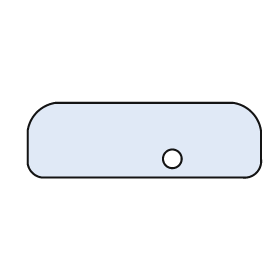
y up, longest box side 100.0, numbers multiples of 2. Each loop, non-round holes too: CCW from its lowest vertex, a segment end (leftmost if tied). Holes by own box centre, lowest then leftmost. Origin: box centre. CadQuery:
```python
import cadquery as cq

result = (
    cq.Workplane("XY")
    .moveTo(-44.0, -16.0)
    .lineTo(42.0, -16.0)
    .threePointArc((48.0, -14.0), (50.0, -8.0))
    .lineTo(50.0, 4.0)
    .threePointArc((46.0, 12.0), (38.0, 16.0))
    .lineTo(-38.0, 16.0)
    .threePointArc((-46.0, 12.0), (-50.0, 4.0))
    .lineTo(-50.0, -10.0)
    .threePointArc((-48.0, -14.0), (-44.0, -16.0))
    .close()
    .moveTo(12.0, -8.0)
    .circle(4.0)
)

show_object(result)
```